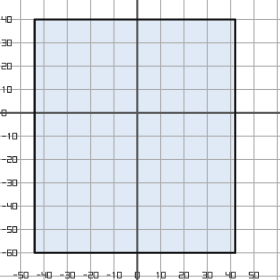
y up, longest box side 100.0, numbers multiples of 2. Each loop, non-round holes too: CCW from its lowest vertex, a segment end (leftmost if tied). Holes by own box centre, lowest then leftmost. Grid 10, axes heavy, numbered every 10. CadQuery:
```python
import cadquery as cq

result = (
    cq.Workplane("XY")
    .moveTo(-44.0, -60.0)
    .lineTo(42.0, -60.0)
    .lineTo(42.0, 40.0)
    .lineTo(-44.0, 40.0)
    .close()
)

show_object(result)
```